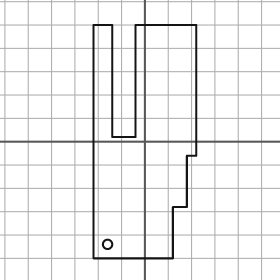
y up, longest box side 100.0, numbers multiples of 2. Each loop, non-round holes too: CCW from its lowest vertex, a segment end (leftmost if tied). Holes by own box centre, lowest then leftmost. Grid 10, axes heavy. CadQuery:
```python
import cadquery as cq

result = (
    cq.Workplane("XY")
    .moveTo(-22.0, -50.0)
    .lineTo(12.0, -50.0)
    .lineTo(12.0, -28.0)
    .lineTo(18.0, -28.0)
    .lineTo(18.0, -6.0)
    .lineTo(22.0, -6.0)
    .lineTo(22.0, 50.0)
    .lineTo(-4.0, 50.0)
    .lineTo(-4.0, 2.0)
    .lineTo(-14.0, 2.0)
    .lineTo(-14.0, 50.0)
    .lineTo(-22.0, 50.0)
    .close()
    .moveTo(-16.0, -44.0)
    .circle(2.0)
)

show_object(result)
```